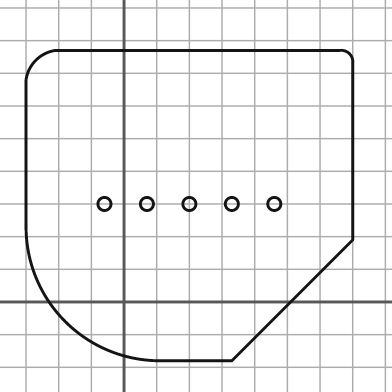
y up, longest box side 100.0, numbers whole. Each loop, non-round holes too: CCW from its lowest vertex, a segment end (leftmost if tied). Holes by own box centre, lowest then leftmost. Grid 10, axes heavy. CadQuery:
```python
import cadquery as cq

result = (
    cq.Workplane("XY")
    .moveTo(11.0, -18.0)
    .lineTo(33.0, -18.0)
    .lineTo(70.0, 19.0)
    .lineTo(70.0, 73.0)
    .threePointArc((69.0, 76.0), (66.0, 77.0))
    .lineTo(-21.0, 77.0)
    .threePointArc((-27.0, 74.0), (-30.0, 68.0))
    .lineTo(-30.0, 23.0)
    .threePointArc((-18.0, -6.0), (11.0, -18.0))
    .close()
    .moveTo(-6.0, 30.0)
    .circle(2.0)
    .moveTo(7.0, 30.0)
    .circle(2.0)
    .moveTo(20.0, 30.0)
    .circle(2.0)
    .moveTo(33.0, 30.0)
    .circle(2.0)
    .moveTo(46.0, 30.0)
    .circle(2.0)
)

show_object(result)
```